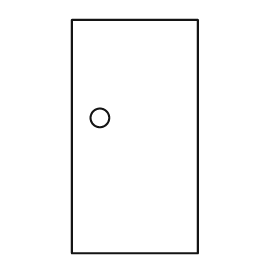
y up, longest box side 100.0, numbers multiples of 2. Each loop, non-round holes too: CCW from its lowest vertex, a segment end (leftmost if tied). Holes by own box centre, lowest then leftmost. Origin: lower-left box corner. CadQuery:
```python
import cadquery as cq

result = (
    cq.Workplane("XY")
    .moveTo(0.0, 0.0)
    .lineTo(54.0, 0.0)
    .lineTo(54.0, 100.0)
    .lineTo(0.0, 100.0)
    .close()
    .moveTo(12.0, 58.0)
    .circle(4.0)
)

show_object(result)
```